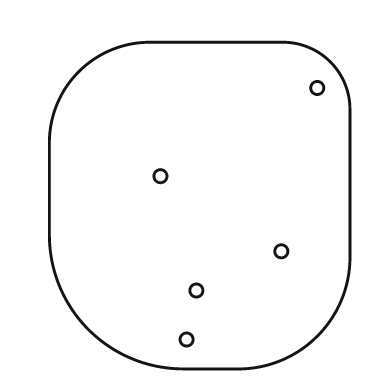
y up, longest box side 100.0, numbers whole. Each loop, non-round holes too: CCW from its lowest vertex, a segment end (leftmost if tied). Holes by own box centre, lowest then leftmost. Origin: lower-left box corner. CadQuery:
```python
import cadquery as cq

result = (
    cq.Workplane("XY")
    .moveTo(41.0, 0.0)
    .lineTo(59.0, 0.0)
    .threePointArc((82.0, 10.0), (92.0, 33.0))
    .lineTo(92.0, 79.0)
    .threePointArc((86.0, 94.0), (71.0, 100.0))
    .lineTo(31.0, 100.0)
    .threePointArc((9.0, 91.0), (0.0, 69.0))
    .lineTo(0.0, 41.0)
    .threePointArc((12.0, 12.0), (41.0, 0.0))
    .close()
    .moveTo(42.0, 9.0)
    .circle(2.0)
    .moveTo(45.0, 24.0)
    .circle(2.0)
    .moveTo(71.0, 36.0)
    .circle(2.0)
    .moveTo(34.0, 59.0)
    .circle(2.0)
    .moveTo(82.0, 86.0)
    .circle(2.0)
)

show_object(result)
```